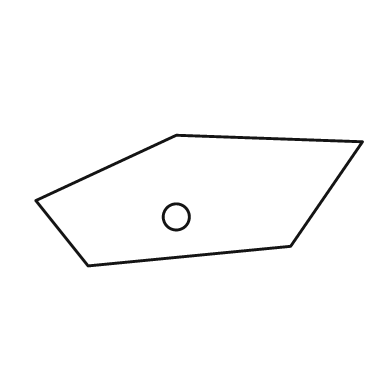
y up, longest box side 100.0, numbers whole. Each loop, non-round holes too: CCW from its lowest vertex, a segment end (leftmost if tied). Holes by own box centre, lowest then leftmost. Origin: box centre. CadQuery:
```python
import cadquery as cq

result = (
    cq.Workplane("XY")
    .moveTo(-34.0, -20.0)
    .lineTo(28.0, -14.0)
    .lineTo(50.0, 18.0)
    .lineTo(-7.0, 20.0)
    .lineTo(-50.0, 0.0)
    .close()
    .moveTo(-7.0, -5.0)
    .circle(4.0)
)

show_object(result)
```